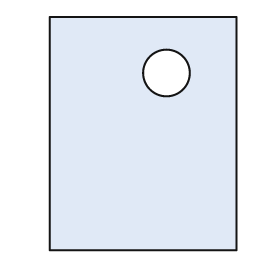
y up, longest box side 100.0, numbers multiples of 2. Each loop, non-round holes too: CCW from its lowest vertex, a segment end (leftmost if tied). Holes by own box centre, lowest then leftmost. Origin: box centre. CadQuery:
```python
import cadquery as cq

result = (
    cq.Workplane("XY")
    .moveTo(-40.0, -50.0)
    .lineTo(40.0, -50.0)
    .lineTo(40.0, 50.0)
    .lineTo(-40.0, 50.0)
    .close()
    .moveTo(10.0, 26.0)
    .circle(10.0)
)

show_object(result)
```